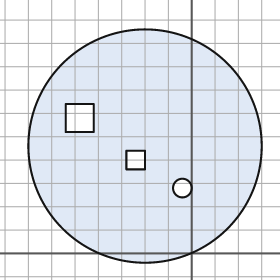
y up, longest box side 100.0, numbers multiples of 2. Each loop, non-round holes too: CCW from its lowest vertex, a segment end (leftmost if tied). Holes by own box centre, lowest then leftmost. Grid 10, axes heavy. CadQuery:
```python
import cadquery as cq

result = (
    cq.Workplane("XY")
    .moveTo(-20.0, 46.0)
    .circle(50.0)
    .moveTo(-4.0, 28.0)
    .circle(4.0)
    .moveTo(-28.0, 36.0)
    .lineTo(-20.0, 36.0)
    .lineTo(-20.0, 44.0)
    .lineTo(-28.0, 44.0)
    .close()
    .moveTo(-54.0, 52.0)
    .lineTo(-42.0, 52.0)
    .lineTo(-42.0, 64.0)
    .lineTo(-54.0, 64.0)
    .close()
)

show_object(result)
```